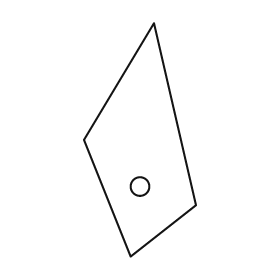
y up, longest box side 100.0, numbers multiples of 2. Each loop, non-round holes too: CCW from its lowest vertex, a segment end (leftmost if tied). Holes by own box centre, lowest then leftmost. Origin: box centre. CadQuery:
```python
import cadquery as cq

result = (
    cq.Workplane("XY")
    .moveTo(-4.0, -50.0)
    .lineTo(24.0, -28.0)
    .lineTo(6.0, 50.0)
    .lineTo(-24.0, 0.0)
    .close()
    .moveTo(0.0, -20.0)
    .circle(4.0)
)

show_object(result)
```